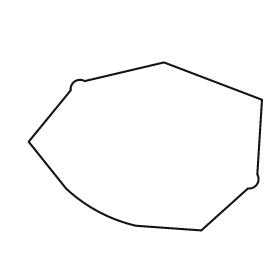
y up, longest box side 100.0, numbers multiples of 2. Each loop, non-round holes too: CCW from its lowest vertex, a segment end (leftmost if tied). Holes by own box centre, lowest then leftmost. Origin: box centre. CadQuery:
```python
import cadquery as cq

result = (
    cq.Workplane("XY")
    .moveTo(24.0, -36.0)
    .lineTo(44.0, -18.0)
    .threePointArc((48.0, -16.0), (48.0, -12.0))
    .lineTo(50.0, 20.0)
    .lineTo(8.0, 36.0)
    .lineTo(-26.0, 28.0)
    .threePointArc((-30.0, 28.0), (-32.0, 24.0))
    .lineTo(-50.0, 2.0)
    .lineTo(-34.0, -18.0)
    .threePointArc((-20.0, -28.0), (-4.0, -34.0))
    .close()
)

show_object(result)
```